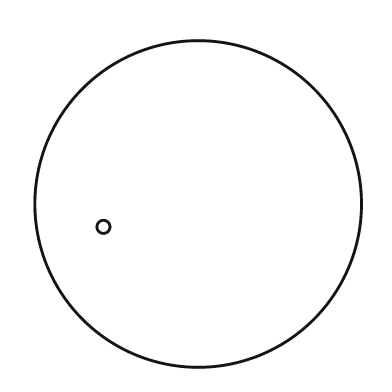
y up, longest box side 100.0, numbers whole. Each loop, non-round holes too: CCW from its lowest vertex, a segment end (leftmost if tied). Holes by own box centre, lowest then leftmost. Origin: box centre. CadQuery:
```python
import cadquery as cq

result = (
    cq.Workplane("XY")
    .moveTo(0.0, 0.0)
    .circle(50.0)
    .moveTo(-29.0, -7.0)
    .circle(2.0)
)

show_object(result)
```